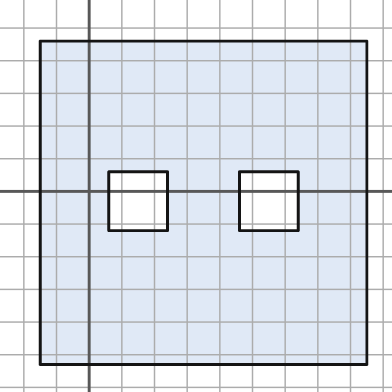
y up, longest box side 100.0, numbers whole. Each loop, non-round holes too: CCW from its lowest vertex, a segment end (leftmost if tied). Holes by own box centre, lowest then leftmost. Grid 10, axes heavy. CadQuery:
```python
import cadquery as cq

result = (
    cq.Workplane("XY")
    .moveTo(-15.0, -53.0)
    .lineTo(85.0, -53.0)
    .lineTo(85.0, 46.0)
    .lineTo(-15.0, 46.0)
    .close()
    .moveTo(6.0, -12.0)
    .lineTo(24.0, -12.0)
    .lineTo(24.0, 6.0)
    .lineTo(6.0, 6.0)
    .close()
    .moveTo(46.0, -12.0)
    .lineTo(64.0, -12.0)
    .lineTo(64.0, 6.0)
    .lineTo(46.0, 6.0)
    .close()
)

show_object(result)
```